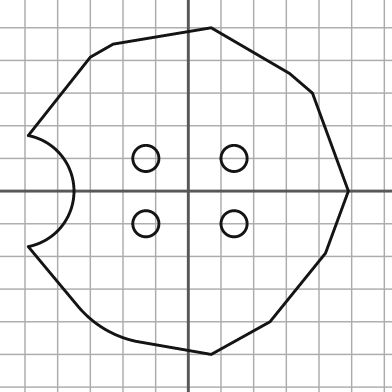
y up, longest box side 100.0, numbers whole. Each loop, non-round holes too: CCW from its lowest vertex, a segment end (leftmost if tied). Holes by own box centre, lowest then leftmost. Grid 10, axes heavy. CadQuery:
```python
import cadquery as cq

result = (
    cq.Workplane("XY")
    .moveTo(7.0, -50.0)
    .lineTo(25.0, -40.0)
    .lineTo(42.0, -19.0)
    .lineTo(49.0, 0.0)
    .lineTo(38.0, 30.0)
    .lineTo(31.0, 36.0)
    .lineTo(7.0, 50.0)
    .lineTo(-23.0, 45.0)
    .lineTo(-30.0, 41.0)
    .lineTo(-49.0, 17.0)
    .threePointArc((-35.0, 0.0), (-49.0, -17.0))
    .lineTo(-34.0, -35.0)
    .threePointArc((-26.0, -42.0), (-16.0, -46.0))
    .close()
    .moveTo(-13.0, -10.0)
    .circle(4.0)
    .moveTo(14.0, -10.0)
    .circle(4.0)
    .moveTo(-13.0, 10.0)
    .circle(4.0)
    .moveTo(14.0, 10.0)
    .circle(4.0)
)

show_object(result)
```